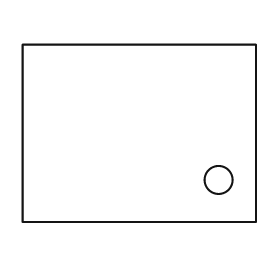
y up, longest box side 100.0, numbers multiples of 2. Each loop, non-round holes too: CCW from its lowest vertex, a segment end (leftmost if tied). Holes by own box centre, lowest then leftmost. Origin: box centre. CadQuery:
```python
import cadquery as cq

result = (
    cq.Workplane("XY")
    .moveTo(-50.0, -38.0)
    .lineTo(50.0, -38.0)
    .lineTo(50.0, 38.0)
    .lineTo(-50.0, 38.0)
    .close()
    .moveTo(34.0, -20.0)
    .circle(6.0)
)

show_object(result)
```